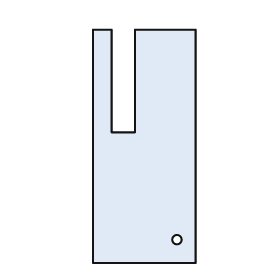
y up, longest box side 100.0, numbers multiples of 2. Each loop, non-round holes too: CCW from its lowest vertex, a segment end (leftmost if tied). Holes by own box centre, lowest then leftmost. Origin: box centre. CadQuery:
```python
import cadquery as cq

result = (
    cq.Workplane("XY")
    .moveTo(-22.0, -50.0)
    .lineTo(22.0, -50.0)
    .lineTo(22.0, 50.0)
    .lineTo(-4.0, 50.0)
    .lineTo(-4.0, 6.0)
    .lineTo(-14.0, 6.0)
    .lineTo(-14.0, 50.0)
    .lineTo(-22.0, 50.0)
    .close()
    .moveTo(14.0, -40.0)
    .circle(2.0)
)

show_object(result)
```